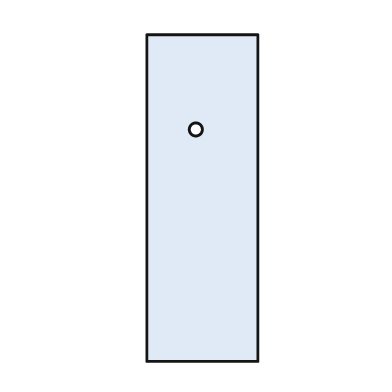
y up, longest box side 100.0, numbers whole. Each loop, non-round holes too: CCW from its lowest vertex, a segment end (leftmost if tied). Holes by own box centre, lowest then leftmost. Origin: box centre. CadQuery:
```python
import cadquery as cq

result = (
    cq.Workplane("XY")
    .moveTo(-17.0, -50.0)
    .lineTo(17.0, -50.0)
    .lineTo(17.0, 50.0)
    .lineTo(-17.0, 50.0)
    .close()
    .moveTo(-2.0, 21.0)
    .circle(2.0)
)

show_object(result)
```